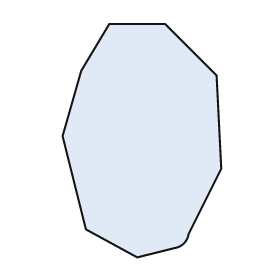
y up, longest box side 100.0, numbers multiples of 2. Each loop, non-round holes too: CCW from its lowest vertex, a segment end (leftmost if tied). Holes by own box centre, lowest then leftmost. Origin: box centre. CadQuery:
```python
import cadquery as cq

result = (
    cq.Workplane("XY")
    .moveTo(-2.0, -50.0)
    .lineTo(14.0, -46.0)
    .threePointArc((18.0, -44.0), (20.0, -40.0))
    .lineTo(34.0, -12.0)
    .lineTo(32.0, 28.0)
    .lineTo(10.0, 50.0)
    .lineTo(-14.0, 50.0)
    .lineTo(-26.0, 30.0)
    .lineTo(-34.0, 2.0)
    .lineTo(-24.0, -38.0)
    .close()
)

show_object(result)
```